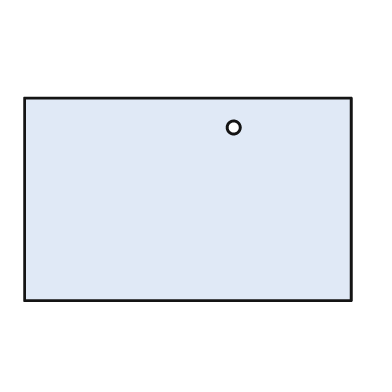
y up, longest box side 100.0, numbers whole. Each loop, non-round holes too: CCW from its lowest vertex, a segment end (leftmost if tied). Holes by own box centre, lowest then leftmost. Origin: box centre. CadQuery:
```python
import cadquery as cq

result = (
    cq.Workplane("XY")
    .moveTo(-50.0, -31.0)
    .lineTo(50.0, -31.0)
    .lineTo(50.0, 31.0)
    .lineTo(-50.0, 31.0)
    .close()
    .moveTo(14.0, 22.0)
    .circle(2.0)
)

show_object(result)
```